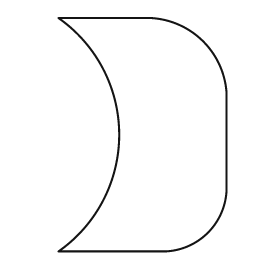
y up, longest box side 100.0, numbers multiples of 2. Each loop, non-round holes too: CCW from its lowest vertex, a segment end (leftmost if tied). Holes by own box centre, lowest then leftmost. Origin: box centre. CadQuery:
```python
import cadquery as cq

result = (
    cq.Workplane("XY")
    .moveTo(-36.0, -50.0)
    .lineTo(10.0, -50.0)
    .threePointArc((28.0, -42.0), (36.0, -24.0))
    .lineTo(36.0, 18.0)
    .threePointArc((26.0, 40.0), (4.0, 50.0))
    .lineTo(-36.0, 50.0)
    .threePointArc((-10.0, 0.0), (-36.0, -50.0))
    .close()
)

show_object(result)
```